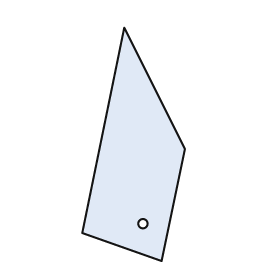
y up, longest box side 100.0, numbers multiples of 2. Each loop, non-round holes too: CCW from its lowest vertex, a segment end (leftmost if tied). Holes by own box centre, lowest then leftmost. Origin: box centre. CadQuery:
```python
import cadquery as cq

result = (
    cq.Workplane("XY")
    .moveTo(12.0, -50.0)
    .lineTo(22.0, -2.0)
    .lineTo(-4.0, 50.0)
    .lineTo(-22.0, -38.0)
    .close()
    .moveTo(4.0, -34.0)
    .circle(2.0)
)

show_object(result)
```